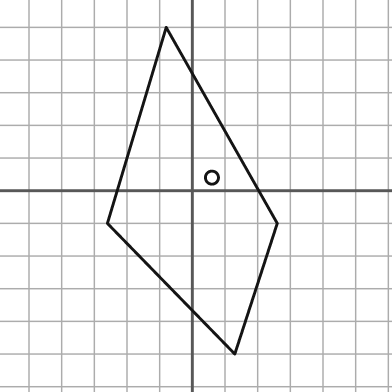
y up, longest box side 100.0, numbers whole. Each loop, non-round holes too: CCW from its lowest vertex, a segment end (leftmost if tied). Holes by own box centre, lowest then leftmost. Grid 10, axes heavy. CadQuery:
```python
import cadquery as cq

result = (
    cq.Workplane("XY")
    .moveTo(13.0, -50.0)
    .lineTo(26.0, -10.0)
    .lineTo(-8.0, 50.0)
    .lineTo(-26.0, -10.0)
    .close()
    .moveTo(6.0, 4.0)
    .circle(2.0)
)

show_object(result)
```